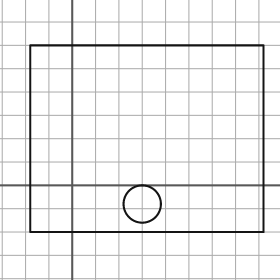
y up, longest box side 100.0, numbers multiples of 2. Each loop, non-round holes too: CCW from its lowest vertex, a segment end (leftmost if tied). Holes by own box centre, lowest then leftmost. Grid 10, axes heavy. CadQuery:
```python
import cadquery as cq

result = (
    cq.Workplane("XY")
    .moveTo(-18.0, -20.0)
    .lineTo(82.0, -20.0)
    .lineTo(82.0, 60.0)
    .lineTo(-18.0, 60.0)
    .close()
    .moveTo(30.0, -8.0)
    .circle(8.0)
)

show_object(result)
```